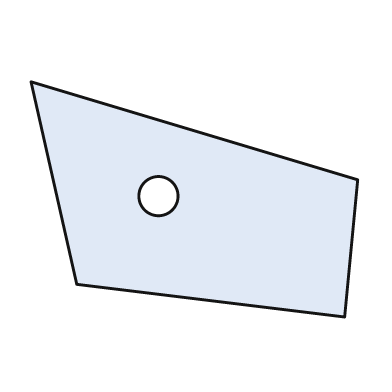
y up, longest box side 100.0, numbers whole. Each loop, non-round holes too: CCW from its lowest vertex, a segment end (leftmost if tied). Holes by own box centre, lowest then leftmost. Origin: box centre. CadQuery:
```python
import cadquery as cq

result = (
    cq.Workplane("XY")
    .moveTo(46.0, -36.0)
    .lineTo(50.0, 6.0)
    .lineTo(-50.0, 36.0)
    .lineTo(-36.0, -26.0)
    .close()
    .moveTo(-11.0, 1.0)
    .circle(6.0)
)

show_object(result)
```